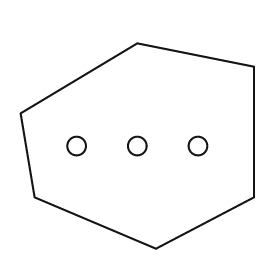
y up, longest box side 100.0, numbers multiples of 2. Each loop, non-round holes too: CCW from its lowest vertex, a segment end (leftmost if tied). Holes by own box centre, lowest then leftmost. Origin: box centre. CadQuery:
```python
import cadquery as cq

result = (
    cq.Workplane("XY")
    .moveTo(8.0, -44.0)
    .lineTo(50.0, -22.0)
    .lineTo(50.0, 34.0)
    .lineTo(0.0, 44.0)
    .lineTo(-50.0, 14.0)
    .lineTo(-44.0, -22.0)
    .close()
    .moveTo(-26.0, 0.0)
    .circle(4.0)
    .moveTo(0.0, 0.0)
    .circle(4.0)
    .moveTo(26.0, 0.0)
    .circle(4.0)
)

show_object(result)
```